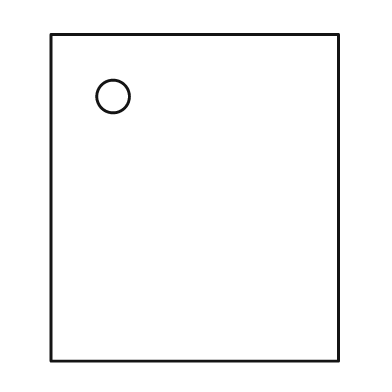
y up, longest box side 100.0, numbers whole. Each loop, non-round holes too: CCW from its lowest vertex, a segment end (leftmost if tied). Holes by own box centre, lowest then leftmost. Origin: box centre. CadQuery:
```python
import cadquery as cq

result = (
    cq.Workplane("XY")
    .moveTo(-44.0, -50.0)
    .lineTo(44.0, -50.0)
    .lineTo(44.0, 50.0)
    .lineTo(-44.0, 50.0)
    .close()
    .moveTo(-25.0, 31.0)
    .circle(5.0)
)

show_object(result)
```